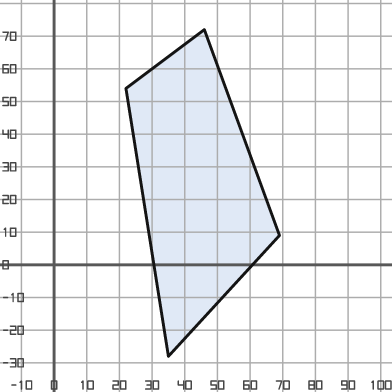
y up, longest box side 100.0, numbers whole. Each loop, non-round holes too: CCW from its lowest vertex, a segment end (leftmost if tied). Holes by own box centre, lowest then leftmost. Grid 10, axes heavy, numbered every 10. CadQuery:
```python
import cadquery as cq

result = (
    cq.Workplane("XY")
    .moveTo(35.0, -28.0)
    .lineTo(69.0, 9.0)
    .lineTo(46.0, 72.0)
    .lineTo(22.0, 54.0)
    .close()
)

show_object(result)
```